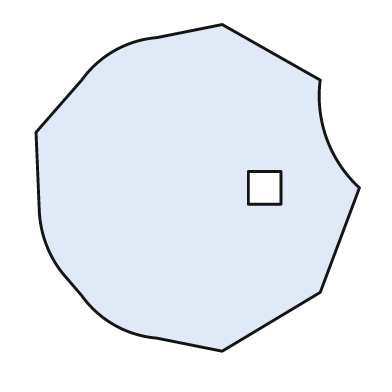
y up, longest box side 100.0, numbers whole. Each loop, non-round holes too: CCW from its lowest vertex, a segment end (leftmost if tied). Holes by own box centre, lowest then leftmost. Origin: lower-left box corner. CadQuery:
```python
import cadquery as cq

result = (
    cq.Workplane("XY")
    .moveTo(57.0, 0.0)
    .lineTo(87.0, 18.0)
    .lineTo(99.0, 50.0)
    .threePointArc((89.0, 65.0), (87.0, 83.0))
    .lineTo(57.0, 100.0)
    .lineTo(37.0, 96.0)
    .threePointArc((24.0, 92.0), (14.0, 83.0))
    .lineTo(0.0, 67.0)
    .lineTo(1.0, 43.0)
    .threePointArc((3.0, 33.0), (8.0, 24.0))
    .lineTo(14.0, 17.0)
    .threePointArc((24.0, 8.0), (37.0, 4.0))
    .close()
    .moveTo(65.0, 45.0)
    .lineTo(75.0, 45.0)
    .lineTo(75.0, 55.0)
    .lineTo(65.0, 55.0)
    .close()
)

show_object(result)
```